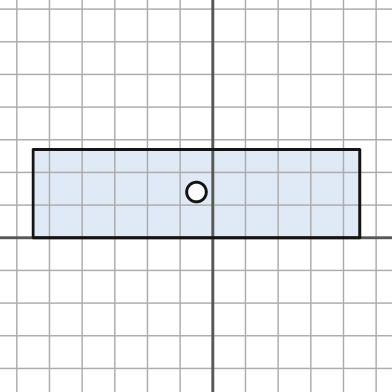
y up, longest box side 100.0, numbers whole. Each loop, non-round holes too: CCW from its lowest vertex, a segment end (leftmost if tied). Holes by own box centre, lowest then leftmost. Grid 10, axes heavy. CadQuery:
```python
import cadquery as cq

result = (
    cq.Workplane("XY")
    .moveTo(-55.0, 0.0)
    .lineTo(45.0, 0.0)
    .lineTo(45.0, 27.0)
    .lineTo(-55.0, 27.0)
    .close()
    .moveTo(-5.0, 14.0)
    .circle(3.0)
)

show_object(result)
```